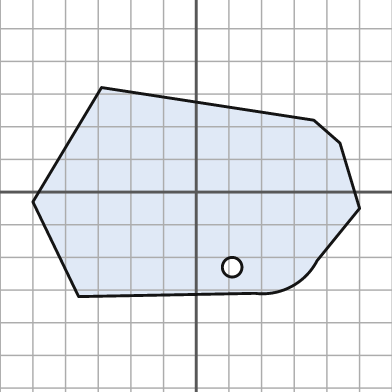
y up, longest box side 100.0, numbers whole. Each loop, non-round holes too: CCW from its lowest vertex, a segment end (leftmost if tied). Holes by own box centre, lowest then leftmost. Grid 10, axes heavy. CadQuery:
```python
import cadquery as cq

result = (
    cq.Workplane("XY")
    .moveTo(-36.0, -32.0)
    .lineTo(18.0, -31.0)
    .threePointArc((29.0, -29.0), (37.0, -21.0))
    .lineTo(50.0, -5.0)
    .lineTo(44.0, 15.0)
    .lineTo(36.0, 22.0)
    .lineTo(-29.0, 32.0)
    .lineTo(-50.0, -3.0)
    .close()
    .moveTo(11.0, -23.0)
    .circle(3.0)
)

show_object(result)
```